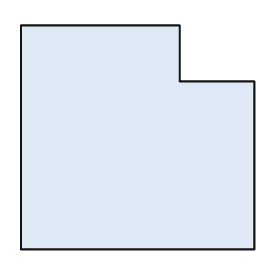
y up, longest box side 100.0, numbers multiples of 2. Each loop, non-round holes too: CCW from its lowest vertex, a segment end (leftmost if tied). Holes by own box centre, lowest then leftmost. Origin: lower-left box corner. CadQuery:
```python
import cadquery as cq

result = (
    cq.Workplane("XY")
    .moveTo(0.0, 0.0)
    .lineTo(100.0, 0.0)
    .lineTo(100.0, 72.0)
    .lineTo(68.0, 72.0)
    .lineTo(68.0, 96.0)
    .lineTo(0.0, 96.0)
    .close()
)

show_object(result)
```